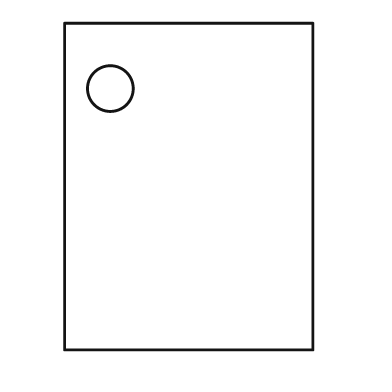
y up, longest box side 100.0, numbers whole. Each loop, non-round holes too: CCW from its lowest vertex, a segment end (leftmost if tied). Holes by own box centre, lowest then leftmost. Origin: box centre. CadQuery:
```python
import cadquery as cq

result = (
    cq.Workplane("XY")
    .moveTo(-38.0, -50.0)
    .lineTo(38.0, -50.0)
    .lineTo(38.0, 50.0)
    .lineTo(-38.0, 50.0)
    .close()
    .moveTo(-24.0, 30.0)
    .circle(7.0)
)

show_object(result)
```